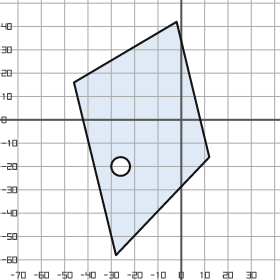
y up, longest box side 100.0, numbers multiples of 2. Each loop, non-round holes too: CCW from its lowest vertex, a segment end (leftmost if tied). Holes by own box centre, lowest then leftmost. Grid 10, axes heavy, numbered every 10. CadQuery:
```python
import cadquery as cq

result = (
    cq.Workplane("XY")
    .moveTo(-28.0, -58.0)
    .lineTo(12.0, -16.0)
    .lineTo(-2.0, 42.0)
    .lineTo(-46.0, 16.0)
    .close()
    .moveTo(-26.0, -20.0)
    .circle(4.0)
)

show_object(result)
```